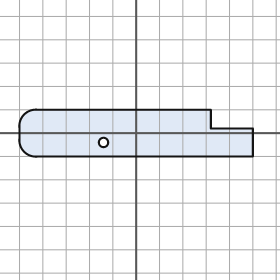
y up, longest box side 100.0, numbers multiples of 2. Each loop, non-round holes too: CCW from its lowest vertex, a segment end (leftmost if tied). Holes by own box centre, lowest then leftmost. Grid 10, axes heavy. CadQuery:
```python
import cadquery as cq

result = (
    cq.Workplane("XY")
    .moveTo(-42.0, -10.0)
    .lineTo(50.0, -10.0)
    .lineTo(50.0, 2.0)
    .lineTo(32.0, 2.0)
    .lineTo(32.0, 10.0)
    .lineTo(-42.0, 10.0)
    .threePointArc((-48.0, 8.0), (-50.0, 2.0))
    .lineTo(-50.0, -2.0)
    .threePointArc((-48.0, -8.0), (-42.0, -10.0))
    .close()
    .moveTo(-14.0, -4.0)
    .circle(2.0)
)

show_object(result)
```